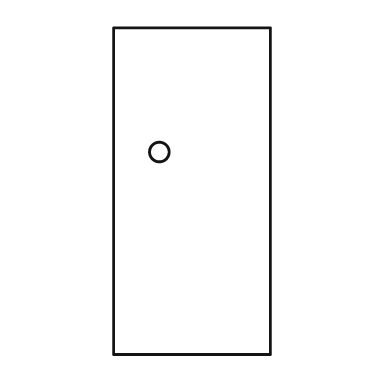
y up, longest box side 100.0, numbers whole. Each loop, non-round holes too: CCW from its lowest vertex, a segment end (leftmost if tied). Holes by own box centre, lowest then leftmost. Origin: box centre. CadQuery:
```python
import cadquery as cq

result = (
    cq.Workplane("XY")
    .moveTo(-24.0, -50.0)
    .lineTo(24.0, -50.0)
    .lineTo(24.0, 50.0)
    .lineTo(-24.0, 50.0)
    .close()
    .moveTo(-10.0, 12.0)
    .circle(3.0)
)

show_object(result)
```